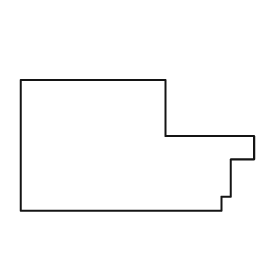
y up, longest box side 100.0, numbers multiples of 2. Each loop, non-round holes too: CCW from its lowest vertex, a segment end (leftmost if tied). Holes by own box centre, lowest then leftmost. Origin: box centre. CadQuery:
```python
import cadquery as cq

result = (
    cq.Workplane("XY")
    .moveTo(-50.0, -28.0)
    .lineTo(36.0, -28.0)
    .lineTo(36.0, -22.0)
    .lineTo(40.0, -22.0)
    .lineTo(40.0, -6.0)
    .lineTo(50.0, -6.0)
    .lineTo(50.0, 4.0)
    .lineTo(12.0, 4.0)
    .lineTo(12.0, 28.0)
    .lineTo(-50.0, 28.0)
    .close()
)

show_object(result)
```